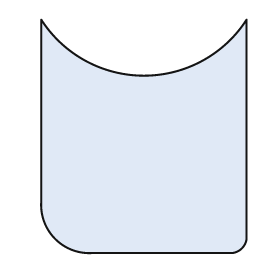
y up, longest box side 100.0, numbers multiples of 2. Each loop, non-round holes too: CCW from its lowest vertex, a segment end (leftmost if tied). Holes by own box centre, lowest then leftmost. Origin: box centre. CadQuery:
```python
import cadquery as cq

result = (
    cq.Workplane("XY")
    .moveTo(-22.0, -50.0)
    .lineTo(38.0, -50.0)
    .threePointArc((42.0, -48.0), (44.0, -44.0))
    .lineTo(44.0, 50.0)
    .threePointArc((0.0, 26.0), (-44.0, 50.0))
    .lineTo(-44.0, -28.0)
    .threePointArc((-38.0, -44.0), (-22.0, -50.0))
    .close()
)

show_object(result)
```